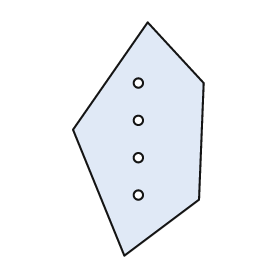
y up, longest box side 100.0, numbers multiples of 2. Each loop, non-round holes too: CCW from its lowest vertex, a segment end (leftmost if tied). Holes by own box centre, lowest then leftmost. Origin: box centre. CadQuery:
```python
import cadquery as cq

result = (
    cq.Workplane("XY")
    .moveTo(-6.0, -50.0)
    .lineTo(26.0, -26.0)
    .lineTo(28.0, 24.0)
    .lineTo(4.0, 50.0)
    .lineTo(-28.0, 4.0)
    .close()
    .moveTo(0.0, -24.0)
    .circle(2.0)
    .moveTo(0.0, -8.0)
    .circle(2.0)
    .moveTo(0.0, 8.0)
    .circle(2.0)
    .moveTo(0.0, 24.0)
    .circle(2.0)
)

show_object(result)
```